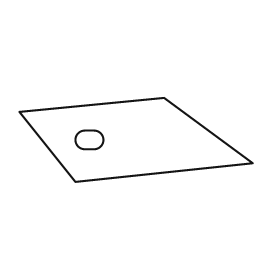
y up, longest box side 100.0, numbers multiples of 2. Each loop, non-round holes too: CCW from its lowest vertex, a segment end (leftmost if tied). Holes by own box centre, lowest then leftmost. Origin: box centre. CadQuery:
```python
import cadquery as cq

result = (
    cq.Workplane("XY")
    .moveTo(-26.0, -18.0)
    .lineTo(50.0, -10.0)
    .lineTo(12.0, 18.0)
    .lineTo(-50.0, 12.0)
    .close()
    .moveTo(-22.0, -4.0)
    .lineTo(-18.0, -4.0)
    .threePointArc((-14.0, 0.0), (-18.0, 4.0))
    .lineTo(-22.0, 4.0)
    .threePointArc((-26.0, 0.0), (-22.0, -4.0))
    .close()
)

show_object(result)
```